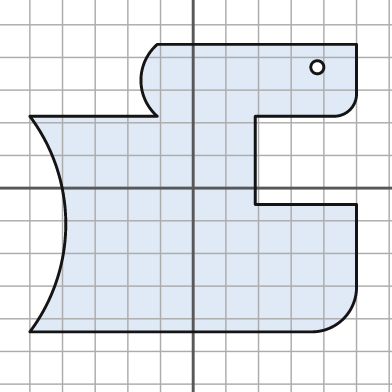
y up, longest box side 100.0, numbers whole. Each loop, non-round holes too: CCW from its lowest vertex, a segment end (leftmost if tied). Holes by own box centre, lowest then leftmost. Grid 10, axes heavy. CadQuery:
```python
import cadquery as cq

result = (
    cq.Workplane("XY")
    .moveTo(-50.0, -44.0)
    .lineTo(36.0, -44.0)
    .threePointArc((46.0, -40.0), (50.0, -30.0))
    .lineTo(50.0, -5.0)
    .lineTo(19.0, -5.0)
    .lineTo(19.0, 22.0)
    .lineTo(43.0, 22.0)
    .threePointArc((48.0, 24.0), (50.0, 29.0))
    .lineTo(50.0, 44.0)
    .lineTo(-11.0, 44.0)
    .threePointArc((-16.0, 33.0), (-11.0, 22.0))
    .lineTo(-50.0, 22.0)
    .threePointArc((-39.0, -11.0), (-50.0, -44.0))
    .close()
    .moveTo(38.0, 37.0)
    .circle(2.0)
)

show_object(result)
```